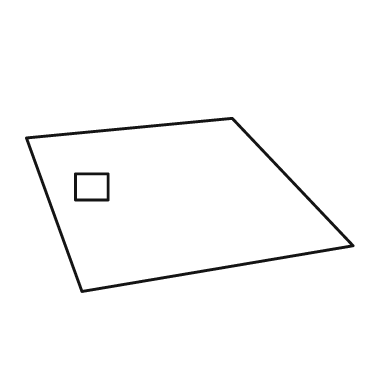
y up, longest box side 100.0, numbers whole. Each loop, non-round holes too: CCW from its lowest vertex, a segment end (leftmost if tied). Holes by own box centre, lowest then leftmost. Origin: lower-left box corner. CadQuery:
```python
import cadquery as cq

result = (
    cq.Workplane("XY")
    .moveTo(17.0, 0.0)
    .lineTo(100.0, 14.0)
    .lineTo(63.0, 53.0)
    .lineTo(0.0, 47.0)
    .close()
    .moveTo(15.0, 28.0)
    .lineTo(25.0, 28.0)
    .lineTo(25.0, 36.0)
    .lineTo(15.0, 36.0)
    .close()
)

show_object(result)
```